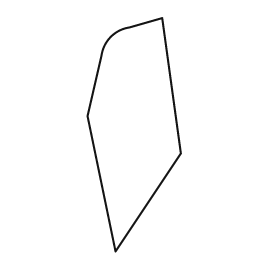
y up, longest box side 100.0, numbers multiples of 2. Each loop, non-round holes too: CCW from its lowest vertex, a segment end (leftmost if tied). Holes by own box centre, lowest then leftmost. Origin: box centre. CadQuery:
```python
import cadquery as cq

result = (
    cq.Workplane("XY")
    .moveTo(-8.0, -50.0)
    .lineTo(20.0, -8.0)
    .lineTo(12.0, 50.0)
    .lineTo(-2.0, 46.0)
    .threePointArc((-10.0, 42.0), (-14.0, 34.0))
    .lineTo(-20.0, 8.0)
    .close()
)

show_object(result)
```